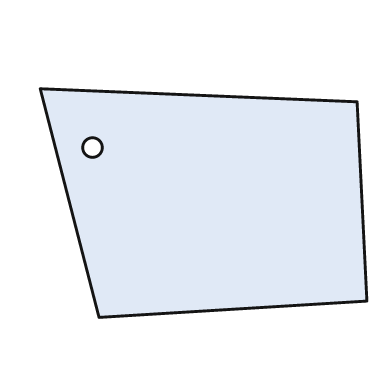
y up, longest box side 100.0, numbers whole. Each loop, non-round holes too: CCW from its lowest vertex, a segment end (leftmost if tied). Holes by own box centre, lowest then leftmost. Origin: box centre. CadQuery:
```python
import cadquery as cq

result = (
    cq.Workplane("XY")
    .moveTo(-32.0, -35.0)
    .lineTo(50.0, -30.0)
    .lineTo(47.0, 31.0)
    .lineTo(-50.0, 35.0)
    .close()
    .moveTo(-34.0, 17.0)
    .circle(3.0)
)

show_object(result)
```